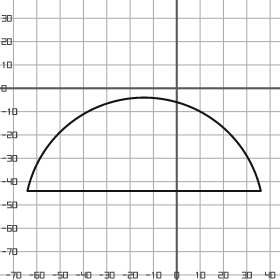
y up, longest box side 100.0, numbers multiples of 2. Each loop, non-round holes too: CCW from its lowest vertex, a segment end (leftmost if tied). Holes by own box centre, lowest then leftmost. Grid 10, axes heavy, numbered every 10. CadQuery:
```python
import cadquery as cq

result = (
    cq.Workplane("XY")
    .moveTo(-64.0, -44.0)
    .lineTo(36.0, -44.0)
    .threePointArc((-14.0, -4.0), (-64.0, -44.0))
    .close()
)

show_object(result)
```